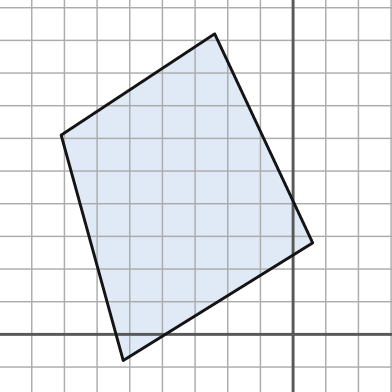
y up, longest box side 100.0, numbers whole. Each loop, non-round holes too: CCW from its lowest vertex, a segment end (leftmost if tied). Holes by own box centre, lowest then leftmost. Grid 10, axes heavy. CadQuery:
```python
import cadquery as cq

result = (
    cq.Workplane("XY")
    .moveTo(-52.0, -8.0)
    .lineTo(6.0, 28.0)
    .lineTo(-24.0, 92.0)
    .lineTo(-71.0, 61.0)
    .close()
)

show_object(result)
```